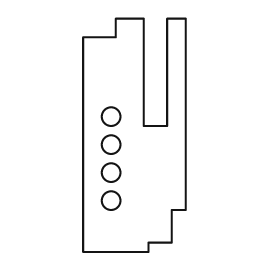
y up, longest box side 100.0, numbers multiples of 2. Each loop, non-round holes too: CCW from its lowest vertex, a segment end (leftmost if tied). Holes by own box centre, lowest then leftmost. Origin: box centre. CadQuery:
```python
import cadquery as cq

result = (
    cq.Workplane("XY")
    .moveTo(-22.0, -50.0)
    .lineTo(6.0, -50.0)
    .lineTo(6.0, -46.0)
    .lineTo(16.0, -46.0)
    .lineTo(16.0, -32.0)
    .lineTo(22.0, -32.0)
    .lineTo(22.0, 50.0)
    .lineTo(14.0, 50.0)
    .lineTo(14.0, 4.0)
    .lineTo(4.0, 4.0)
    .lineTo(4.0, 50.0)
    .lineTo(-8.0, 50.0)
    .lineTo(-8.0, 42.0)
    .lineTo(-22.0, 42.0)
    .close()
    .moveTo(-10.0, -28.0)
    .circle(4.0)
    .moveTo(-10.0, -16.0)
    .circle(4.0)
    .moveTo(-10.0, -4.0)
    .circle(4.0)
    .moveTo(-10.0, 8.0)
    .circle(4.0)
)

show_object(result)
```